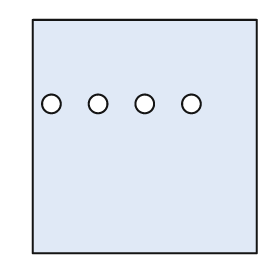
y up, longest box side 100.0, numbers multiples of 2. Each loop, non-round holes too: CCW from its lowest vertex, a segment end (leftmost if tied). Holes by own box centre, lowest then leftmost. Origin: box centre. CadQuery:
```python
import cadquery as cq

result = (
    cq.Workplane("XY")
    .moveTo(-48.0, -50.0)
    .lineTo(48.0, -50.0)
    .lineTo(48.0, 50.0)
    .lineTo(-48.0, 50.0)
    .close()
    .moveTo(-40.0, 14.0)
    .circle(4.0)
    .moveTo(-20.0, 14.0)
    .circle(4.0)
    .moveTo(0.0, 14.0)
    .circle(4.0)
    .moveTo(20.0, 14.0)
    .circle(4.0)
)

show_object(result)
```